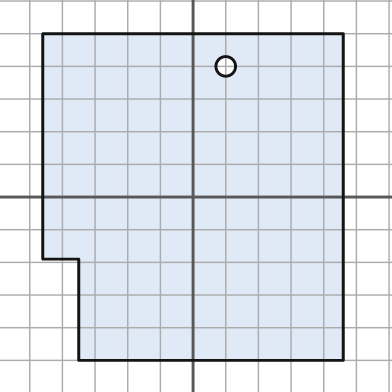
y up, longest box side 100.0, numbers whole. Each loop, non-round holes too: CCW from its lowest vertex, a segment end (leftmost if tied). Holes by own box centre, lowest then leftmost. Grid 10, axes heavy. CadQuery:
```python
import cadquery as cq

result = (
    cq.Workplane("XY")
    .moveTo(-35.0, -50.0)
    .lineTo(46.0, -50.0)
    .lineTo(46.0, 50.0)
    .lineTo(-46.0, 50.0)
    .lineTo(-46.0, -19.0)
    .lineTo(-35.0, -19.0)
    .close()
    .moveTo(10.0, 40.0)
    .circle(3.0)
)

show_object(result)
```